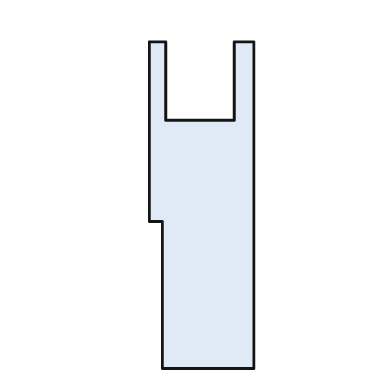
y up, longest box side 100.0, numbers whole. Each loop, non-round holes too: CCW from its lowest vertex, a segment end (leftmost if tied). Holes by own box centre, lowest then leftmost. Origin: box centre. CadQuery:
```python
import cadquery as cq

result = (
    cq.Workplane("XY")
    .moveTo(-12.0, -50.0)
    .lineTo(16.0, -50.0)
    .lineTo(16.0, 50.0)
    .lineTo(10.0, 50.0)
    .lineTo(10.0, 26.0)
    .lineTo(-11.0, 26.0)
    .lineTo(-11.0, 50.0)
    .lineTo(-16.0, 50.0)
    .lineTo(-16.0, -5.0)
    .lineTo(-12.0, -5.0)
    .close()
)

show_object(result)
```